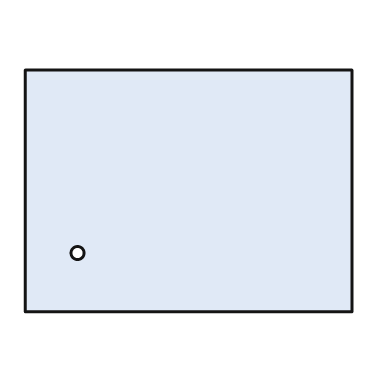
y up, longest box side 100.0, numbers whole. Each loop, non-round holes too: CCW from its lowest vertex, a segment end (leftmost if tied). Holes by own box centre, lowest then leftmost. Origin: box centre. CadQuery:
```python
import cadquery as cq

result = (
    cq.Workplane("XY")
    .moveTo(-50.0, -37.0)
    .lineTo(50.0, -37.0)
    .lineTo(50.0, 37.0)
    .lineTo(-50.0, 37.0)
    .close()
    .moveTo(-34.0, -19.0)
    .circle(2.0)
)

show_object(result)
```